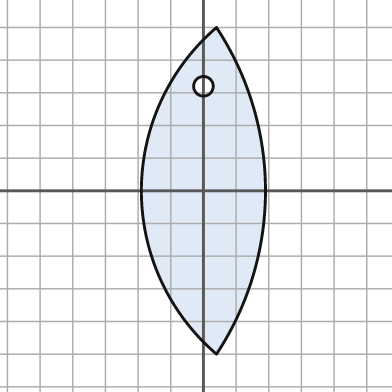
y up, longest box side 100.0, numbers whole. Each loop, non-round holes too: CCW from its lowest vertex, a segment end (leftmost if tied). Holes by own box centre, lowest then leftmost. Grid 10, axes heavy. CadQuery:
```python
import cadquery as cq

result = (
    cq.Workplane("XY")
    .moveTo(4.0, -50.0)
    .threePointArc((19.0, 0.0), (4.0, 50.0))
    .threePointArc((-19.0, 0.0), (4.0, -50.0))
    .close()
    .moveTo(0.0, 32.0)
    .circle(3.0)
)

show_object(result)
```